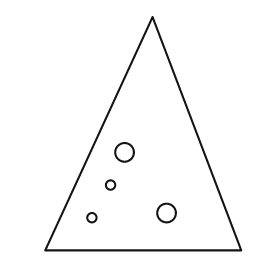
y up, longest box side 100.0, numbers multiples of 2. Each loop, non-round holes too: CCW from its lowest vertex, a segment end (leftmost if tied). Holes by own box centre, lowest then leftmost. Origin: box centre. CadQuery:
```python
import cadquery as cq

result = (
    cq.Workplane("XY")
    .moveTo(-42.0, -50.0)
    .lineTo(42.0, -50.0)
    .lineTo(4.0, 50.0)
    .close()
    .moveTo(-22.0, -36.0)
    .circle(2.0)
    .moveTo(10.0, -34.0)
    .circle(4.0)
    .moveTo(-14.0, -22.0)
    .circle(2.0)
    .moveTo(-8.0, -8.0)
    .circle(4.0)
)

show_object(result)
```